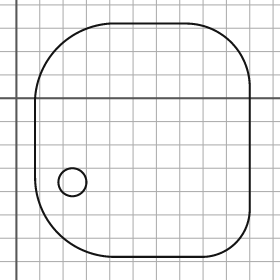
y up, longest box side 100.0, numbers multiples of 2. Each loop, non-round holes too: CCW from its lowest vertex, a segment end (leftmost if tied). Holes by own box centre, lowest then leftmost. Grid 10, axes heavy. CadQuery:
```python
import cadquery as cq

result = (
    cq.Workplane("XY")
    .moveTo(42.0, -68.0)
    .lineTo(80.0, -68.0)
    .threePointArc((94.0, -62.0), (100.0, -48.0))
    .lineTo(100.0, 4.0)
    .threePointArc((92.0, 24.0), (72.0, 32.0))
    .lineTo(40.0, 32.0)
    .threePointArc((18.0, 22.0), (8.0, 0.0))
    .lineTo(8.0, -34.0)
    .threePointArc((18.0, -58.0), (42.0, -68.0))
    .close()
    .moveTo(24.0, -36.0)
    .circle(6.0)
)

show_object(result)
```